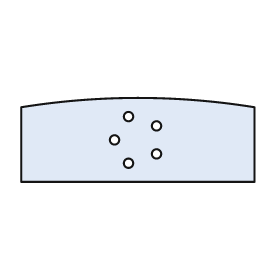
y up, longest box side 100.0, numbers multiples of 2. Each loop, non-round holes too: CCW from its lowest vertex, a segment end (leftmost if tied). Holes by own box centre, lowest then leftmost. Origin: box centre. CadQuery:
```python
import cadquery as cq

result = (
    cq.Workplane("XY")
    .moveTo(-50.0, -18.0)
    .lineTo(50.0, -18.0)
    .lineTo(50.0, 14.0)
    .threePointArc((0.0, 18.0), (-50.0, 14.0))
    .close()
    .moveTo(-4.0, -10.0)
    .circle(2.0)
    .moveTo(8.0, -6.0)
    .circle(2.0)
    .moveTo(-10.0, 0.0)
    .circle(2.0)
    .moveTo(8.0, 6.0)
    .circle(2.0)
    .moveTo(-4.0, 10.0)
    .circle(2.0)
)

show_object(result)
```